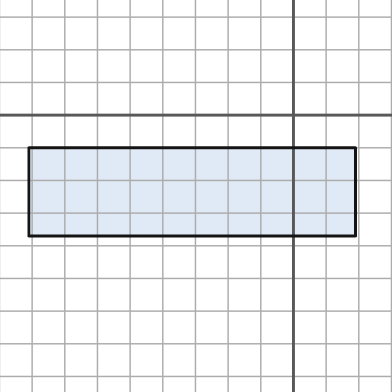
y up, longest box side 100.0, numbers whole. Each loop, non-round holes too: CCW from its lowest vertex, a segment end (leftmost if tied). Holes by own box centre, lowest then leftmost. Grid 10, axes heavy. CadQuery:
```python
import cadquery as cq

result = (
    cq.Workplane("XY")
    .moveTo(-81.0, -37.0)
    .lineTo(19.0, -37.0)
    .lineTo(19.0, -10.0)
    .lineTo(-81.0, -10.0)
    .close()
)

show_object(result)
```